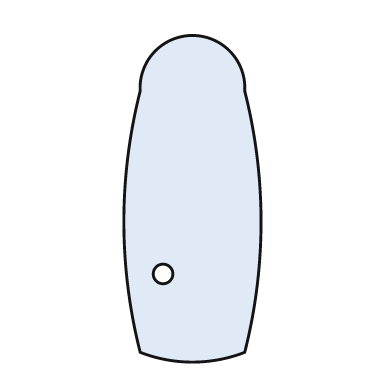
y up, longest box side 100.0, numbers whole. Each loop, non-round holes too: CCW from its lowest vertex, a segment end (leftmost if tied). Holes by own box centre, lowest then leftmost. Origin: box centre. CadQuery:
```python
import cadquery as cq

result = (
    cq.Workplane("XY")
    .moveTo(-16.0, -47.0)
    .threePointArc((0.0, -50.0), (16.0, -47.0))
    .threePointArc((21.0, -7.0), (16.0, 33.0))
    .threePointArc((0.0, 50.0), (-16.0, 33.0))
    .threePointArc((-21.0, -7.0), (-16.0, -47.0))
    .close()
    .moveTo(-9.0, -23.0)
    .circle(3.0)
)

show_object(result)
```